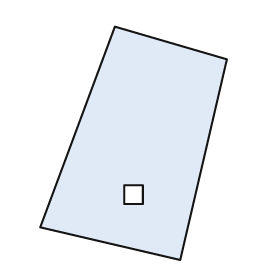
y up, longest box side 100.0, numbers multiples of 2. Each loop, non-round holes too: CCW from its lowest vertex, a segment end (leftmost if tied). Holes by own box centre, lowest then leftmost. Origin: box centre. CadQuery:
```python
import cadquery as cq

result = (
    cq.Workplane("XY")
    .moveTo(20.0, -50.0)
    .lineTo(40.0, 36.0)
    .lineTo(-8.0, 50.0)
    .lineTo(-40.0, -36.0)
    .close()
    .moveTo(-4.0, -26.0)
    .lineTo(4.0, -26.0)
    .lineTo(4.0, -18.0)
    .lineTo(-4.0, -18.0)
    .close()
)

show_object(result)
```